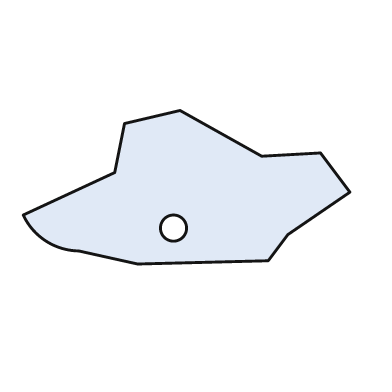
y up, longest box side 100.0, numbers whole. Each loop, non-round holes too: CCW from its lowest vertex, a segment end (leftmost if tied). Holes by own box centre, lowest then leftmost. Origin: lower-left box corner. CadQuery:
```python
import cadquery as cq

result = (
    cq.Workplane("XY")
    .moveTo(35.0, 0.0)
    .lineTo(75.0, 1.0)
    .lineTo(81.0, 9.0)
    .lineTo(100.0, 22.0)
    .lineTo(91.0, 34.0)
    .lineTo(73.0, 33.0)
    .lineTo(48.0, 47.0)
    .lineTo(31.0, 43.0)
    .lineTo(28.0, 28.0)
    .lineTo(0.0, 15.0)
    .threePointArc((7.0, 7.0), (17.0, 4.0))
    .close()
    .moveTo(46.0, 11.0)
    .circle(4.0)
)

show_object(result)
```